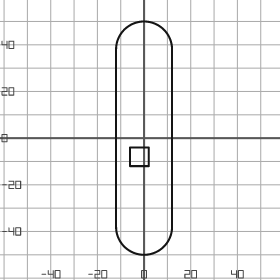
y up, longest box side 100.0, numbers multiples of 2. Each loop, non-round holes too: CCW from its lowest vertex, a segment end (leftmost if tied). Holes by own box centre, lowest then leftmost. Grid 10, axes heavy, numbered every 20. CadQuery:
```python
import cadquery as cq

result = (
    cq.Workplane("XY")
    .moveTo(-12.0, -38.0)
    .threePointArc((0.0, -50.0), (12.0, -38.0))
    .lineTo(12.0, 38.0)
    .threePointArc((0.0, 50.0), (-12.0, 38.0))
    .close()
    .moveTo(-6.0, -12.0)
    .lineTo(2.0, -12.0)
    .lineTo(2.0, -4.0)
    .lineTo(-6.0, -4.0)
    .close()
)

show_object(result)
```